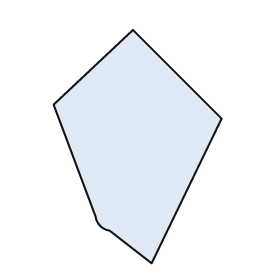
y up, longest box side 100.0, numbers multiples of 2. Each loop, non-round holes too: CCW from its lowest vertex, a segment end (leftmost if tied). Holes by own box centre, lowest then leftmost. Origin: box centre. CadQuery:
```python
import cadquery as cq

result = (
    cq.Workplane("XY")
    .moveTo(6.0, -50.0)
    .lineTo(36.0, 12.0)
    .lineTo(-2.0, 50.0)
    .lineTo(-36.0, 18.0)
    .lineTo(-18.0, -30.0)
    .threePointArc((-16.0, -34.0), (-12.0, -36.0))
    .close()
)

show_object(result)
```